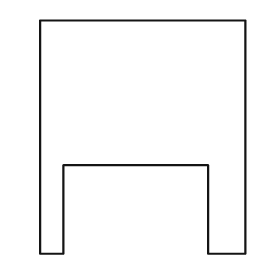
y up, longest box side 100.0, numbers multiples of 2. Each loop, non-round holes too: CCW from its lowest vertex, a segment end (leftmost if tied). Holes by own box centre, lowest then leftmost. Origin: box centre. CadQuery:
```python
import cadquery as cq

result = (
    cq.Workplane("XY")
    .moveTo(-44.0, -50.0)
    .lineTo(-34.0, -50.0)
    .lineTo(-34.0, -12.0)
    .lineTo(28.0, -12.0)
    .lineTo(28.0, -50.0)
    .lineTo(44.0, -50.0)
    .lineTo(44.0, 50.0)
    .lineTo(-44.0, 50.0)
    .close()
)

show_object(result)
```